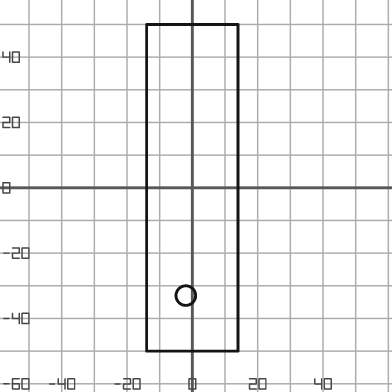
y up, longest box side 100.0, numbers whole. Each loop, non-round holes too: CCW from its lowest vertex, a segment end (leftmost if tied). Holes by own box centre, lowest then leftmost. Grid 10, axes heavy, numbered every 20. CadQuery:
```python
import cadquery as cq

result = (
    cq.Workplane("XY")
    .moveTo(-14.0, -50.0)
    .lineTo(14.0, -50.0)
    .lineTo(14.0, 50.0)
    .lineTo(-14.0, 50.0)
    .close()
    .moveTo(-2.0, -33.0)
    .circle(3.0)
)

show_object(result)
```